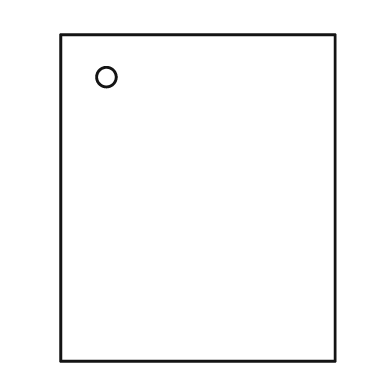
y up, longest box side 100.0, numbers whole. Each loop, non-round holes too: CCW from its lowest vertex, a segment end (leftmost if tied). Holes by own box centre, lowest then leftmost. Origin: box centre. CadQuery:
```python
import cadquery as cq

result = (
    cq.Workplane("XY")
    .moveTo(-42.0, -50.0)
    .lineTo(42.0, -50.0)
    .lineTo(42.0, 50.0)
    .lineTo(-42.0, 50.0)
    .close()
    .moveTo(-28.0, 37.0)
    .circle(3.0)
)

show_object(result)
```